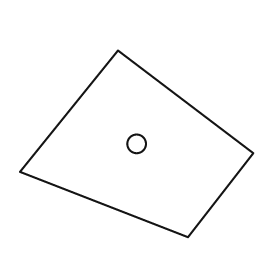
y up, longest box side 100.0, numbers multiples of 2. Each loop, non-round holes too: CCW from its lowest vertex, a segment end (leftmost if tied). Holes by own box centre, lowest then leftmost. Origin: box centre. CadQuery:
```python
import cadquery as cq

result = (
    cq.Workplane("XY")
    .moveTo(22.0, -40.0)
    .lineTo(50.0, -4.0)
    .lineTo(-8.0, 40.0)
    .lineTo(-50.0, -12.0)
    .close()
    .moveTo(0.0, 0.0)
    .circle(4.0)
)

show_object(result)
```